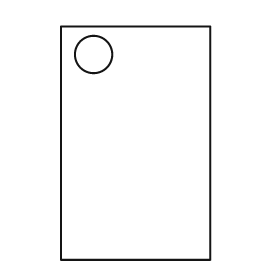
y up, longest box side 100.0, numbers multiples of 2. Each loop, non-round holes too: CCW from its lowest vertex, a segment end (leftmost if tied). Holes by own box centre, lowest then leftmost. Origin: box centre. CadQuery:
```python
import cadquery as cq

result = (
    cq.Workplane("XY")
    .moveTo(-32.0, -50.0)
    .lineTo(32.0, -50.0)
    .lineTo(32.0, 50.0)
    .lineTo(-32.0, 50.0)
    .close()
    .moveTo(-18.0, 38.0)
    .circle(8.0)
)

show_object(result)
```